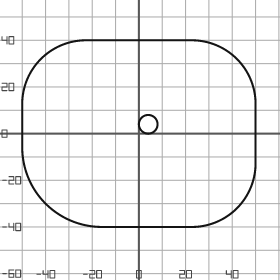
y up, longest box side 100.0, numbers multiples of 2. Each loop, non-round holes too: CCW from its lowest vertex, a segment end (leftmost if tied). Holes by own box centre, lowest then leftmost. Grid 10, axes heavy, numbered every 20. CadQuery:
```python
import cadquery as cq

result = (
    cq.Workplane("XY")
    .moveTo(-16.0, -40.0)
    .lineTo(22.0, -40.0)
    .threePointArc((42.0, -32.0), (50.0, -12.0))
    .lineTo(50.0, 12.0)
    .threePointArc((42.0, 32.0), (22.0, 40.0))
    .lineTo(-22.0, 40.0)
    .threePointArc((-42.0, 32.0), (-50.0, 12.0))
    .lineTo(-50.0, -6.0)
    .threePointArc((-40.0, -30.0), (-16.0, -40.0))
    .close()
    .moveTo(4.0, 4.0)
    .circle(4.0)
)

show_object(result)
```